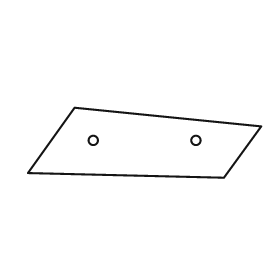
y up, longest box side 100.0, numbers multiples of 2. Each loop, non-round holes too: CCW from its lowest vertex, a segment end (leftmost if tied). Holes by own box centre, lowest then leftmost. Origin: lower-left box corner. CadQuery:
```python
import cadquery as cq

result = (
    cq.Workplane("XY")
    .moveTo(84.0, 0.0)
    .lineTo(100.0, 22.0)
    .lineTo(20.0, 30.0)
    .lineTo(0.0, 2.0)
    .close()
    .moveTo(28.0, 16.0)
    .circle(2.0)
    .moveTo(72.0, 16.0)
    .circle(2.0)
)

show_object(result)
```